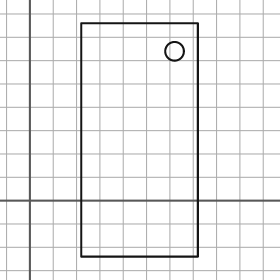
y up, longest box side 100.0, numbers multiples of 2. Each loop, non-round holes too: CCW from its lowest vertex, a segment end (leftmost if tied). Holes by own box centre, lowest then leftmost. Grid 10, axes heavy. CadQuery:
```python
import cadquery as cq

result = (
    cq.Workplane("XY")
    .moveTo(22.0, -24.0)
    .lineTo(72.0, -24.0)
    .lineTo(72.0, 76.0)
    .lineTo(22.0, 76.0)
    .close()
    .moveTo(62.0, 64.0)
    .circle(4.0)
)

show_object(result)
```